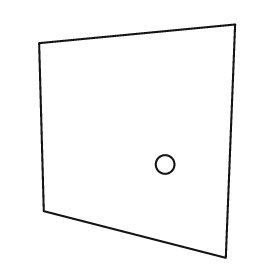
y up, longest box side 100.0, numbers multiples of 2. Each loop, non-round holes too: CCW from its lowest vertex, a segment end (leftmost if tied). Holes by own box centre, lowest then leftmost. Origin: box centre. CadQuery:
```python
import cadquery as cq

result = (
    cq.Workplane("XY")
    .moveTo(38.0, -50.0)
    .lineTo(42.0, 50.0)
    .lineTo(-42.0, 42.0)
    .lineTo(-40.0, -30.0)
    .close()
    .moveTo(12.0, -10.0)
    .circle(4.0)
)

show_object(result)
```